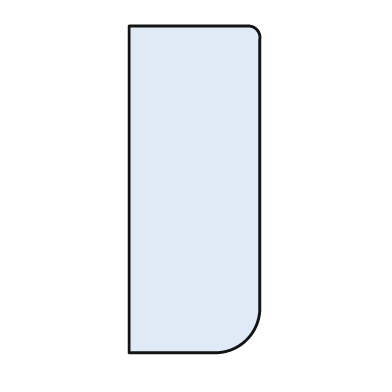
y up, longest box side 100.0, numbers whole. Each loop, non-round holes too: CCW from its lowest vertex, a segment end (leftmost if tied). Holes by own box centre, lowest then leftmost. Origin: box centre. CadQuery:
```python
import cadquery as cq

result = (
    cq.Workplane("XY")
    .moveTo(-20.0, -50.0)
    .lineTo(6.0, -50.0)
    .threePointArc((16.0, -46.0), (20.0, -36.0))
    .lineTo(20.0, 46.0)
    .threePointArc((19.0, 49.0), (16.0, 50.0))
    .lineTo(-20.0, 50.0)
    .close()
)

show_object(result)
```